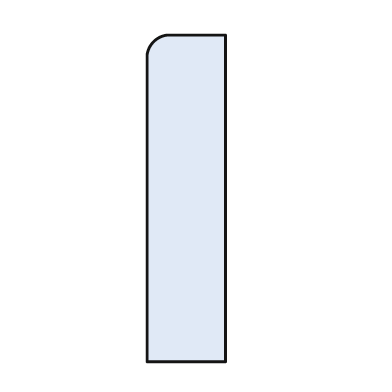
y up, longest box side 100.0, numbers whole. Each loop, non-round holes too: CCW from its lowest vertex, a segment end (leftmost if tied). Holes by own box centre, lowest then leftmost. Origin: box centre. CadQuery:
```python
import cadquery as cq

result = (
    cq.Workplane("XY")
    .moveTo(-12.0, -50.0)
    .lineTo(12.0, -50.0)
    .lineTo(12.0, 50.0)
    .lineTo(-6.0, 50.0)
    .threePointArc((-10.0, 48.0), (-12.0, 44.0))
    .close()
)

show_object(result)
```